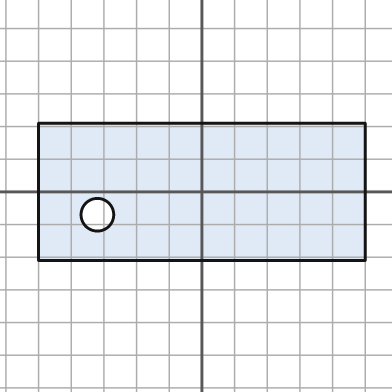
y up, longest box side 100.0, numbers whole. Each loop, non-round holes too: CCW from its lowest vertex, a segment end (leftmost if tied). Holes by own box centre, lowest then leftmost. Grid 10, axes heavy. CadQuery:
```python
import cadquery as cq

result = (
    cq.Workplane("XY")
    .moveTo(-50.0, -21.0)
    .lineTo(50.0, -21.0)
    .lineTo(50.0, 21.0)
    .lineTo(-50.0, 21.0)
    .close()
    .moveTo(-32.0, -7.0)
    .circle(5.0)
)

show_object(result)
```